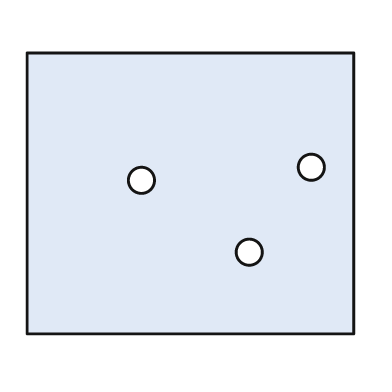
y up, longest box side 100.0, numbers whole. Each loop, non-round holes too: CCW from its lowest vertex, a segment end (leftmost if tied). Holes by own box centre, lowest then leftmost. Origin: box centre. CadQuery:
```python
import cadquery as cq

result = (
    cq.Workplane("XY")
    .moveTo(-50.0, -43.0)
    .lineTo(50.0, -43.0)
    .lineTo(50.0, 43.0)
    .lineTo(-50.0, 43.0)
    .close()
    .moveTo(18.0, -18.0)
    .circle(4.0)
    .moveTo(-15.0, 4.0)
    .circle(4.0)
    .moveTo(37.0, 8.0)
    .circle(4.0)
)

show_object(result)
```